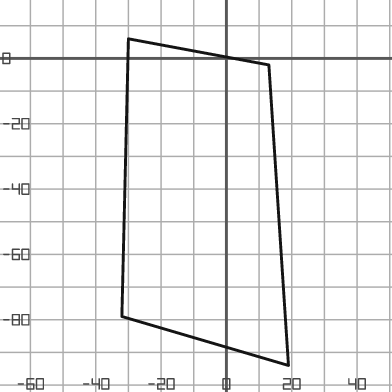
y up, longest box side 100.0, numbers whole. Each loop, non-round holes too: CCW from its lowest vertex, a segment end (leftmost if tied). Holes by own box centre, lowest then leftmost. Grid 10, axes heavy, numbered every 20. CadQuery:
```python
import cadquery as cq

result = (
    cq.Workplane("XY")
    .moveTo(19.0, -94.0)
    .lineTo(13.0, -2.0)
    .lineTo(-30.0, 6.0)
    .lineTo(-32.0, -79.0)
    .close()
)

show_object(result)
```